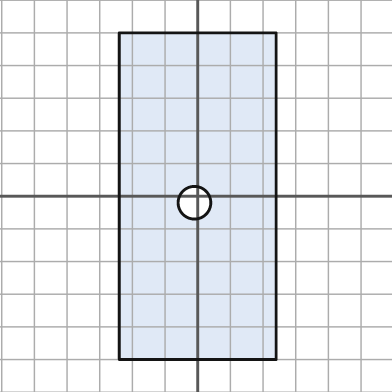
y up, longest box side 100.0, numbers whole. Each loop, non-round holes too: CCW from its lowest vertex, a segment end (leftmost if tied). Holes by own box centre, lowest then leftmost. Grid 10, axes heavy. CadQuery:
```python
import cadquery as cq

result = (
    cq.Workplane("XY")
    .moveTo(-24.0, -50.0)
    .lineTo(24.0, -50.0)
    .lineTo(24.0, 50.0)
    .lineTo(-24.0, 50.0)
    .close()
    .moveTo(-1.0, -2.0)
    .circle(5.0)
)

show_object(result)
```